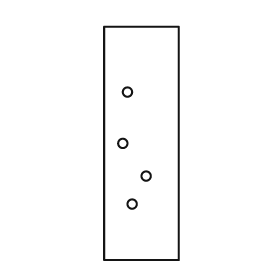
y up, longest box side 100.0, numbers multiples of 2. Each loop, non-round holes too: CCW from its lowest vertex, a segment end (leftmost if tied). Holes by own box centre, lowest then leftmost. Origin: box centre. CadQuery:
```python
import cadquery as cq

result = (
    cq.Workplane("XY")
    .moveTo(-16.0, -50.0)
    .lineTo(16.0, -50.0)
    .lineTo(16.0, 50.0)
    .lineTo(-16.0, 50.0)
    .close()
    .moveTo(-4.0, -26.0)
    .circle(2.0)
    .moveTo(2.0, -14.0)
    .circle(2.0)
    .moveTo(-8.0, 0.0)
    .circle(2.0)
    .moveTo(-6.0, 22.0)
    .circle(2.0)
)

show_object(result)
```